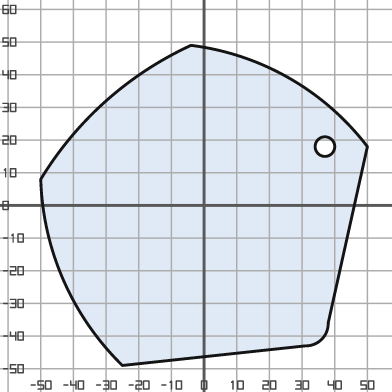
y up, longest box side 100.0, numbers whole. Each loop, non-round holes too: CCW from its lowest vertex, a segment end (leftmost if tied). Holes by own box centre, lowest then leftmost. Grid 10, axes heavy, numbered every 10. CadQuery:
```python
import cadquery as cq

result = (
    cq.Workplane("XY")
    .moveTo(-25.0, -49.0)
    .lineTo(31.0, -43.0)
    .threePointArc((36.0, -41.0), (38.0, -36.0))
    .lineTo(50.0, 18.0)
    .threePointArc((26.0, 39.0), (-4.0, 49.0))
    .threePointArc((-30.0, 32.0), (-50.0, 8.0))
    .threePointArc((-43.0, -23.0), (-25.0, -49.0))
    .close()
    .moveTo(37.0, 18.0)
    .circle(3.0)
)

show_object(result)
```